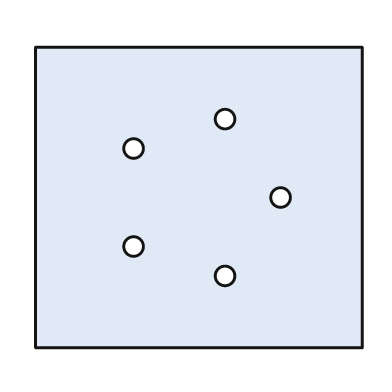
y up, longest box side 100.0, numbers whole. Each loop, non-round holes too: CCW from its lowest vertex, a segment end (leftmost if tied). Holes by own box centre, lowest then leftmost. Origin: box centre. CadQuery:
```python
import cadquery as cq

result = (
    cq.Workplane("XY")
    .moveTo(-50.0, -46.0)
    .lineTo(50.0, -46.0)
    .lineTo(50.0, 46.0)
    .lineTo(-50.0, 46.0)
    .close()
    .moveTo(8.0, -24.0)
    .circle(3.0)
    .moveTo(-20.0, -15.0)
    .circle(3.0)
    .moveTo(25.0, 0.0)
    .circle(3.0)
    .moveTo(-20.0, 15.0)
    .circle(3.0)
    .moveTo(8.0, 24.0)
    .circle(3.0)
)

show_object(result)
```